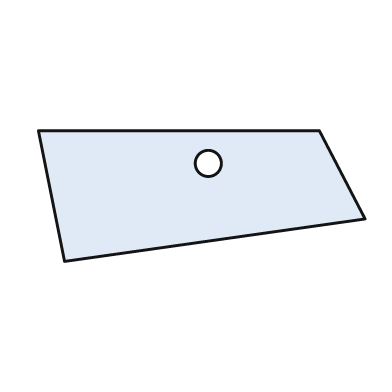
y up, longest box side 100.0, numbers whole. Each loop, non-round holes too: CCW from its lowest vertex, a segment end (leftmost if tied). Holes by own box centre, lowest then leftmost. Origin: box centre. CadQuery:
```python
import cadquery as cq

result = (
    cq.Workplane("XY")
    .moveTo(-42.0, -20.0)
    .lineTo(50.0, -7.0)
    .lineTo(36.0, 20.0)
    .lineTo(-50.0, 20.0)
    .close()
    .moveTo(2.0, 10.0)
    .circle(4.0)
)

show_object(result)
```